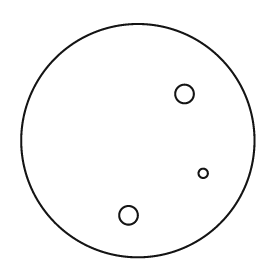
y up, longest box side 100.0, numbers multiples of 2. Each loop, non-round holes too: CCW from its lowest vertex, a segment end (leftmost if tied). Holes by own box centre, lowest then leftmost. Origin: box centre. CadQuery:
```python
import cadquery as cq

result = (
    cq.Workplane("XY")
    .moveTo(0.0, 0.0)
    .circle(50.0)
    .moveTo(-4.0, -32.0)
    .circle(4.0)
    .moveTo(28.0, -14.0)
    .circle(2.0)
    .moveTo(20.0, 20.0)
    .circle(4.0)
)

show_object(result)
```